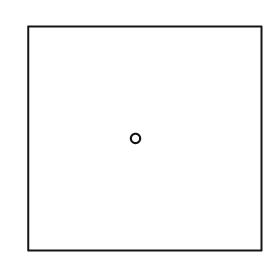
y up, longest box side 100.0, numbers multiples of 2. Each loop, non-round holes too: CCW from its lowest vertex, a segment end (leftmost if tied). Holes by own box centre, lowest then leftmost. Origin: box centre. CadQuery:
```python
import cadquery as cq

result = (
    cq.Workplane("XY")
    .moveTo(-50.0, -48.0)
    .lineTo(50.0, -48.0)
    .lineTo(50.0, 48.0)
    .lineTo(-50.0, 48.0)
    .close()
    .moveTo(-4.0, 0.0)
    .circle(2.0)
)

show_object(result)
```